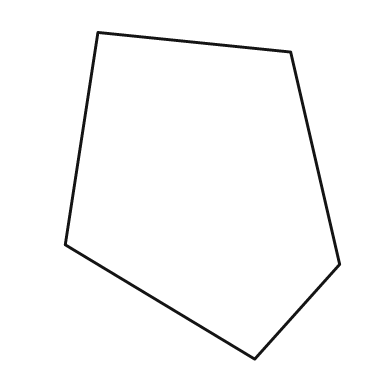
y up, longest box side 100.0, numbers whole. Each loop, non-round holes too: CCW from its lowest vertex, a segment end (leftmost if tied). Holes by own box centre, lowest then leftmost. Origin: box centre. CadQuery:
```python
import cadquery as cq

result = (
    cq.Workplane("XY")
    .moveTo(16.0, -50.0)
    .lineTo(42.0, -21.0)
    .lineTo(27.0, 44.0)
    .lineTo(-32.0, 50.0)
    .lineTo(-42.0, -15.0)
    .close()
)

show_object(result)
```